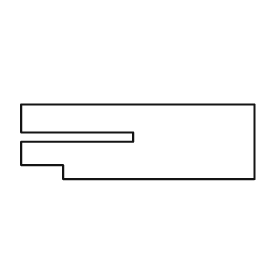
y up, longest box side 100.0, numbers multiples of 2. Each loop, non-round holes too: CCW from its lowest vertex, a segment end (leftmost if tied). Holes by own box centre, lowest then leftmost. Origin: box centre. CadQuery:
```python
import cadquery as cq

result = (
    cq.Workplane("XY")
    .moveTo(-32.0, -16.0)
    .lineTo(50.0, -16.0)
    .lineTo(50.0, 16.0)
    .lineTo(-50.0, 16.0)
    .lineTo(-50.0, 4.0)
    .lineTo(-2.0, 4.0)
    .lineTo(-2.0, 0.0)
    .lineTo(-50.0, 0.0)
    .lineTo(-50.0, -10.0)
    .lineTo(-32.0, -10.0)
    .close()
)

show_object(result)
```